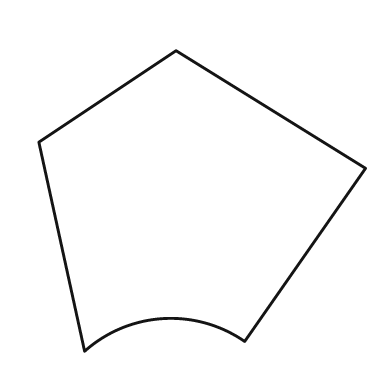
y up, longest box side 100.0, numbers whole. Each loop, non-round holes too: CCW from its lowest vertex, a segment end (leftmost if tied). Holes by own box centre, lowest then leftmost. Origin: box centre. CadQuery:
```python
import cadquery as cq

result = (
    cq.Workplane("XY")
    .moveTo(-36.0, -46.0)
    .threePointArc((-12.0, -36.0), (13.0, -43.0))
    .lineTo(50.0, 10.0)
    .lineTo(-8.0, 46.0)
    .lineTo(-50.0, 18.0)
    .close()
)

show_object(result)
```